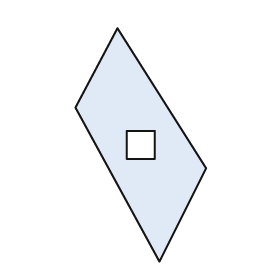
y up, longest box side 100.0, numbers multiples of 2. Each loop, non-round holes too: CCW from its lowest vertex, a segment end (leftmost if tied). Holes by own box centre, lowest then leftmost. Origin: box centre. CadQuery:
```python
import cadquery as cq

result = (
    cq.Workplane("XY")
    .moveTo(8.0, -50.0)
    .lineTo(28.0, -10.0)
    .lineTo(-10.0, 50.0)
    .lineTo(-28.0, 16.0)
    .close()
    .moveTo(-6.0, -6.0)
    .lineTo(6.0, -6.0)
    .lineTo(6.0, 6.0)
    .lineTo(-6.0, 6.0)
    .close()
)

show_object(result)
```